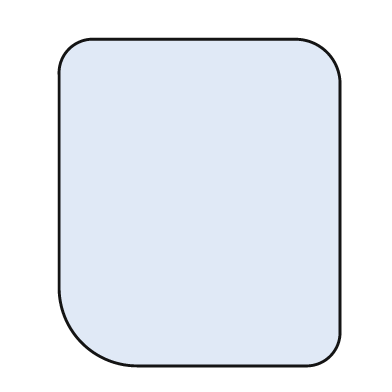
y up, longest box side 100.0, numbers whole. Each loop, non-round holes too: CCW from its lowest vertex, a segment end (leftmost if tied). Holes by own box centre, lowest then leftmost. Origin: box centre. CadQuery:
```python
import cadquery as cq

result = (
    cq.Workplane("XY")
    .moveTo(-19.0, -50.0)
    .lineTo(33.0, -50.0)
    .threePointArc((40.0, -47.0), (43.0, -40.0))
    .lineTo(43.0, 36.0)
    .threePointArc((39.0, 46.0), (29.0, 50.0))
    .lineTo(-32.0, 50.0)
    .threePointArc((-40.0, 47.0), (-43.0, 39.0))
    .lineTo(-43.0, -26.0)
    .threePointArc((-36.0, -43.0), (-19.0, -50.0))
    .close()
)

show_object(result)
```